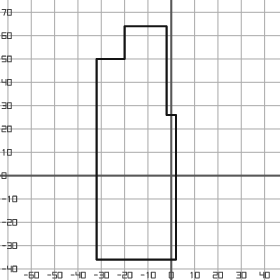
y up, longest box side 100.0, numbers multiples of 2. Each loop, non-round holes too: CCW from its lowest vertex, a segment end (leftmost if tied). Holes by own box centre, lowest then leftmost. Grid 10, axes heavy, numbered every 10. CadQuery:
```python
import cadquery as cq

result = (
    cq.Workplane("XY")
    .moveTo(-32.0, -36.0)
    .lineTo(2.0, -36.0)
    .lineTo(2.0, 26.0)
    .lineTo(-2.0, 26.0)
    .lineTo(-2.0, 64.0)
    .lineTo(-20.0, 64.0)
    .lineTo(-20.0, 50.0)
    .lineTo(-32.0, 50.0)
    .close()
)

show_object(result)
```